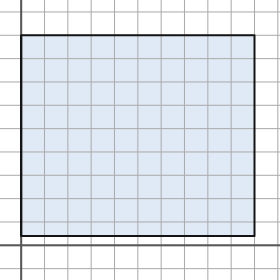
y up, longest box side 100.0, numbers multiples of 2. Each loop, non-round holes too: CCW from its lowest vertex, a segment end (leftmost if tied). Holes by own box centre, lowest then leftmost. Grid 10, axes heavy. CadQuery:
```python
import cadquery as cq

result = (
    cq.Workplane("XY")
    .moveTo(0.0, 4.0)
    .lineTo(100.0, 4.0)
    .lineTo(100.0, 90.0)
    .lineTo(0.0, 90.0)
    .close()
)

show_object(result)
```